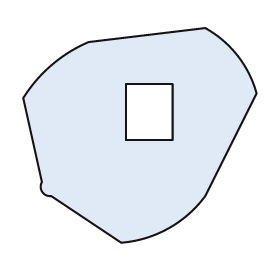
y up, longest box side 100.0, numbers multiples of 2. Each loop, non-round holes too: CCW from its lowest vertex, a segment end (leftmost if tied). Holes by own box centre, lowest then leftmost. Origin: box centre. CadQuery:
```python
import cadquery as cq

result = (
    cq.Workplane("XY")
    .moveTo(-8.0, -46.0)
    .threePointArc((12.0, -40.0), (28.0, -26.0))
    .lineTo(50.0, 18.0)
    .threePointArc((42.0, 34.0), (28.0, 46.0))
    .lineTo(-22.0, 40.0)
    .threePointArc((-38.0, 30.0), (-50.0, 16.0))
    .lineTo(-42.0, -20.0)
    .threePointArc((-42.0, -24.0), (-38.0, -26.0))
    .close()
    .moveTo(-6.0, -2.0)
    .lineTo(14.0, -2.0)
    .lineTo(14.0, 22.0)
    .lineTo(-6.0, 22.0)
    .close()
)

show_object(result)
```